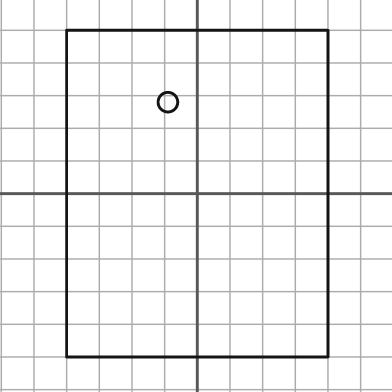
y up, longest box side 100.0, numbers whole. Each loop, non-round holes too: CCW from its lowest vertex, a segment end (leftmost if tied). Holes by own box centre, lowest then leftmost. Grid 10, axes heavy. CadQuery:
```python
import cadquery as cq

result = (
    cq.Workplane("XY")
    .moveTo(-40.0, -50.0)
    .lineTo(40.0, -50.0)
    .lineTo(40.0, 50.0)
    .lineTo(-40.0, 50.0)
    .close()
    .moveTo(-9.0, 28.0)
    .circle(3.0)
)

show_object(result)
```